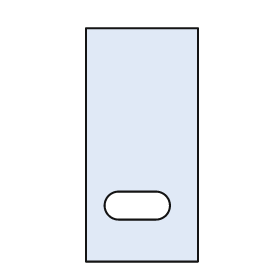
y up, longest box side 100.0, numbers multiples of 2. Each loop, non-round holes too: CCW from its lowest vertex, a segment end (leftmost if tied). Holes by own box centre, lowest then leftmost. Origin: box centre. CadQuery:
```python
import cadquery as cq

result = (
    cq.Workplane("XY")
    .moveTo(-24.0, -50.0)
    .lineTo(24.0, -50.0)
    .lineTo(24.0, 50.0)
    .lineTo(-24.0, 50.0)
    .close()
    .moveTo(-10.0, -32.0)
    .lineTo(6.0, -32.0)
    .threePointArc((12.0, -26.0), (6.0, -20.0))
    .lineTo(-10.0, -20.0)
    .threePointArc((-16.0, -26.0), (-10.0, -32.0))
    .close()
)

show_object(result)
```